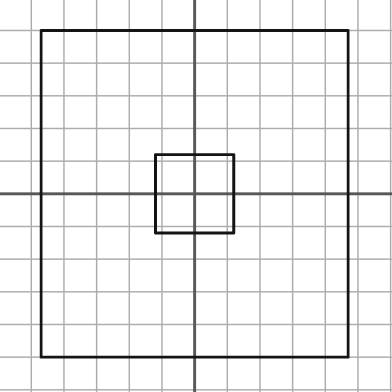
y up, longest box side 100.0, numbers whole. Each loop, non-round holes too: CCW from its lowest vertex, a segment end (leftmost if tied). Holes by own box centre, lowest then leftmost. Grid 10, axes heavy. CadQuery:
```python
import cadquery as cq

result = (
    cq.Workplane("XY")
    .moveTo(-47.0, -50.0)
    .lineTo(47.0, -50.0)
    .lineTo(47.0, 50.0)
    .lineTo(-47.0, 50.0)
    .close()
    .moveTo(-12.0, -12.0)
    .lineTo(12.0, -12.0)
    .lineTo(12.0, 12.0)
    .lineTo(-12.0, 12.0)
    .close()
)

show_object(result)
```